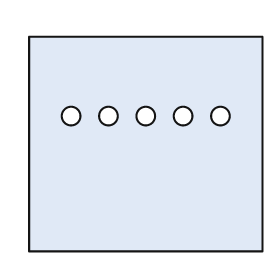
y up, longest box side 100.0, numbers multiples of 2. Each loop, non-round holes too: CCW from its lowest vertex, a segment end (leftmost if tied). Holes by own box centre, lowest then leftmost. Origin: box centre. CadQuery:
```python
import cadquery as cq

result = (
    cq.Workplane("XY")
    .moveTo(-50.0, -46.0)
    .lineTo(50.0, -46.0)
    .lineTo(50.0, 46.0)
    .lineTo(-50.0, 46.0)
    .close()
    .moveTo(-32.0, 12.0)
    .circle(4.0)
    .moveTo(-16.0, 12.0)
    .circle(4.0)
    .moveTo(0.0, 12.0)
    .circle(4.0)
    .moveTo(16.0, 12.0)
    .circle(4.0)
    .moveTo(32.0, 12.0)
    .circle(4.0)
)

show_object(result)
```